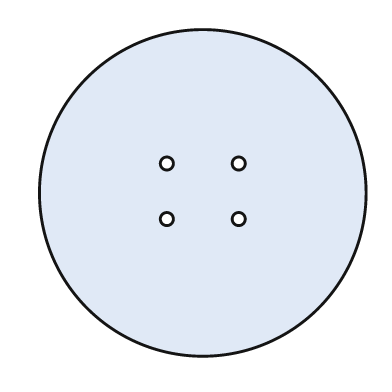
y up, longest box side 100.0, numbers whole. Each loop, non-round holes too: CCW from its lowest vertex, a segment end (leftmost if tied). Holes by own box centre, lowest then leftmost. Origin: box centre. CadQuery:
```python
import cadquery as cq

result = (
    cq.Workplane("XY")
    .moveTo(0.0, 0.0)
    .circle(50.0)
    .moveTo(-11.0, -8.0)
    .circle(2.0)
    .moveTo(11.0, -8.0)
    .circle(2.0)
    .moveTo(-11.0, 9.0)
    .circle(2.0)
    .moveTo(11.0, 9.0)
    .circle(2.0)
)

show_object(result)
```